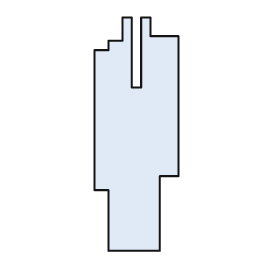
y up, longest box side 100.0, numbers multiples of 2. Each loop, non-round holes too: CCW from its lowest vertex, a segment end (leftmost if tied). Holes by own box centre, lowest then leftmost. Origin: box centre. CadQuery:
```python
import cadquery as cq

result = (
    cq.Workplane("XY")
    .moveTo(-12.0, -50.0)
    .lineTo(10.0, -50.0)
    .lineTo(10.0, -18.0)
    .lineTo(18.0, -18.0)
    .lineTo(18.0, 42.0)
    .lineTo(6.0, 42.0)
    .lineTo(6.0, 50.0)
    .lineTo(2.0, 50.0)
    .lineTo(2.0, 20.0)
    .lineTo(-2.0, 20.0)
    .lineTo(-2.0, 50.0)
    .lineTo(-6.0, 50.0)
    .lineTo(-6.0, 40.0)
    .lineTo(-12.0, 40.0)
    .lineTo(-12.0, 36.0)
    .lineTo(-18.0, 36.0)
    .lineTo(-18.0, -24.0)
    .lineTo(-12.0, -24.0)
    .close()
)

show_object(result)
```